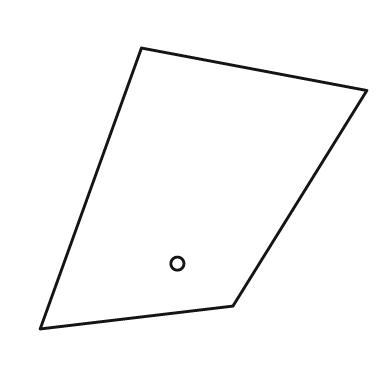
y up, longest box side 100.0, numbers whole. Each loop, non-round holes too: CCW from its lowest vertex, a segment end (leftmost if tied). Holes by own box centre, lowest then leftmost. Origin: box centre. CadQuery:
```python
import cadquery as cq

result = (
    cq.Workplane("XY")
    .moveTo(-50.0, -43.0)
    .lineTo(9.0, -36.0)
    .lineTo(50.0, 30.0)
    .lineTo(-19.0, 43.0)
    .close()
    .moveTo(-8.0, -23.0)
    .circle(2.0)
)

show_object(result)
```